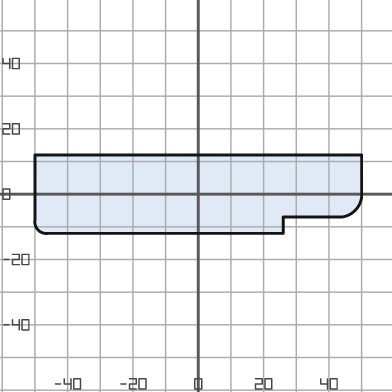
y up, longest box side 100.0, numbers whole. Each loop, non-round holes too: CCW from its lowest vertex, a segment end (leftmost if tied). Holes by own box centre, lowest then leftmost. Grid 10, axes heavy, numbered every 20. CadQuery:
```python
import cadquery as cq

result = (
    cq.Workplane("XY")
    .moveTo(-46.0, -12.0)
    .lineTo(26.0, -12.0)
    .lineTo(26.0, -7.0)
    .lineTo(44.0, -7.0)
    .threePointArc((48.0, -5.0), (50.0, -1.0))
    .lineTo(50.0, 12.0)
    .lineTo(-50.0, 12.0)
    .lineTo(-50.0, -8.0)
    .threePointArc((-49.0, -11.0), (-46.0, -12.0))
    .close()
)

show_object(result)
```